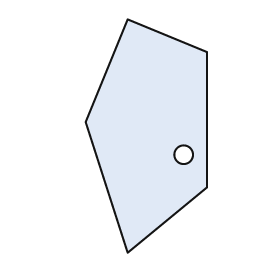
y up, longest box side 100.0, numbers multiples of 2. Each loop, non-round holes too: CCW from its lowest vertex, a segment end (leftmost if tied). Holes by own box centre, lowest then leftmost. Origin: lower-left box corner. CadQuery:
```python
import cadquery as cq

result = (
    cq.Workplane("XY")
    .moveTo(18.0, 0.0)
    .lineTo(52.0, 28.0)
    .lineTo(52.0, 86.0)
    .lineTo(18.0, 100.0)
    .lineTo(0.0, 56.0)
    .close()
    .moveTo(42.0, 42.0)
    .circle(4.0)
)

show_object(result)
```